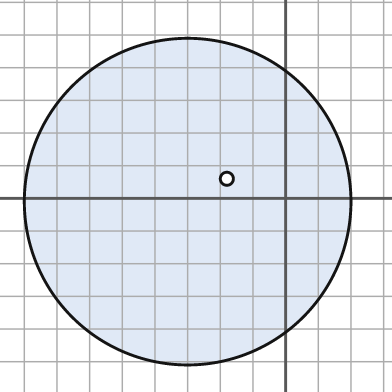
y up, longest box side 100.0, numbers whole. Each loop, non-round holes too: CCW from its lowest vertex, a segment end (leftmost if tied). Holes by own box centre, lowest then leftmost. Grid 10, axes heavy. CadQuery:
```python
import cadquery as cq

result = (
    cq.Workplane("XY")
    .moveTo(-30.0, -1.0)
    .circle(50.0)
    .moveTo(-18.0, 6.0)
    .circle(2.0)
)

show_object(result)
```